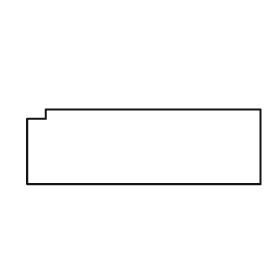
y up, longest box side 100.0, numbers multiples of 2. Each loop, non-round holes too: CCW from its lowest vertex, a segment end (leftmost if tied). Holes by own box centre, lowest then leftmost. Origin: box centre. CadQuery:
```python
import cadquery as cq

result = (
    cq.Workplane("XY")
    .moveTo(-50.0, -16.0)
    .lineTo(50.0, -16.0)
    .lineTo(50.0, 16.0)
    .lineTo(-42.0, 16.0)
    .lineTo(-42.0, 12.0)
    .lineTo(-50.0, 12.0)
    .close()
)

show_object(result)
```